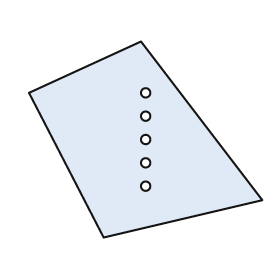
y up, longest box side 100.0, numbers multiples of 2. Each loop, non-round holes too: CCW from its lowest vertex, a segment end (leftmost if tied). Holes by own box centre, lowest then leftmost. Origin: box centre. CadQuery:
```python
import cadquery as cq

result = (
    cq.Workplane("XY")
    .moveTo(-18.0, -42.0)
    .lineTo(50.0, -26.0)
    .lineTo(-2.0, 42.0)
    .lineTo(-50.0, 20.0)
    .close()
    .moveTo(0.0, -20.0)
    .circle(2.0)
    .moveTo(0.0, -10.0)
    .circle(2.0)
    .moveTo(0.0, 0.0)
    .circle(2.0)
    .moveTo(0.0, 10.0)
    .circle(2.0)
    .moveTo(0.0, 20.0)
    .circle(2.0)
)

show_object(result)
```